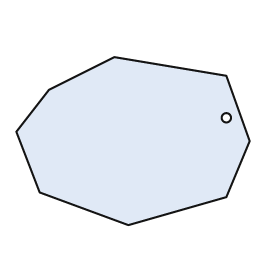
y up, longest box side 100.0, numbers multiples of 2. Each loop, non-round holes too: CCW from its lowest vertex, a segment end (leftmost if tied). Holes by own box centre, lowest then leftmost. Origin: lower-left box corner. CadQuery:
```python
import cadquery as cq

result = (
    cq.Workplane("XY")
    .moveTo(48.0, 0.0)
    .lineTo(90.0, 12.0)
    .lineTo(100.0, 36.0)
    .lineTo(90.0, 64.0)
    .lineTo(42.0, 72.0)
    .lineTo(14.0, 58.0)
    .lineTo(0.0, 40.0)
    .lineTo(10.0, 14.0)
    .close()
    .moveTo(90.0, 46.0)
    .circle(2.0)
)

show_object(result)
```